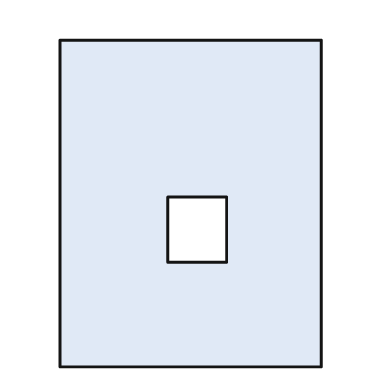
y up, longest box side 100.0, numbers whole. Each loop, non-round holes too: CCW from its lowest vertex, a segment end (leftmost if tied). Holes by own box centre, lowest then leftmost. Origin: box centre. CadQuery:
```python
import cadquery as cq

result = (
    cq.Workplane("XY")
    .moveTo(-40.0, -50.0)
    .lineTo(40.0, -50.0)
    .lineTo(40.0, 50.0)
    .lineTo(-40.0, 50.0)
    .close()
    .moveTo(-7.0, -18.0)
    .lineTo(11.0, -18.0)
    .lineTo(11.0, 2.0)
    .lineTo(-7.0, 2.0)
    .close()
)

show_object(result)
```